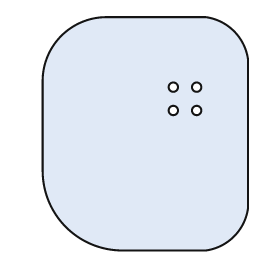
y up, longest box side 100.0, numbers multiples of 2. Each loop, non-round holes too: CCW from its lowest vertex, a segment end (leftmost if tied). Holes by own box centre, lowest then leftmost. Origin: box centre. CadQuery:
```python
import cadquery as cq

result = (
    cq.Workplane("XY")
    .moveTo(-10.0, -50.0)
    .lineTo(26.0, -50.0)
    .threePointArc((38.0, -44.0), (44.0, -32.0))
    .lineTo(44.0, 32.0)
    .threePointArc((38.0, 44.0), (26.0, 50.0))
    .lineTo(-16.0, 50.0)
    .threePointArc((-36.0, 42.0), (-44.0, 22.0))
    .lineTo(-44.0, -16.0)
    .threePointArc((-34.0, -40.0), (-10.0, -50.0))
    .close()
    .moveTo(12.0, 10.0)
    .circle(2.0)
    .moveTo(22.0, 10.0)
    .circle(2.0)
    .moveTo(12.0, 20.0)
    .circle(2.0)
    .moveTo(22.0, 20.0)
    .circle(2.0)
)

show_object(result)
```